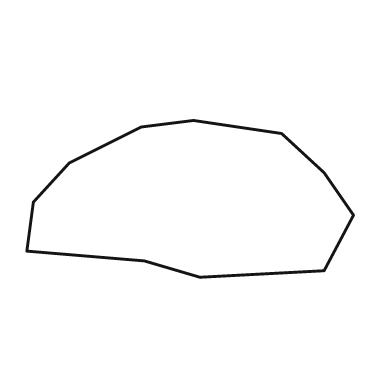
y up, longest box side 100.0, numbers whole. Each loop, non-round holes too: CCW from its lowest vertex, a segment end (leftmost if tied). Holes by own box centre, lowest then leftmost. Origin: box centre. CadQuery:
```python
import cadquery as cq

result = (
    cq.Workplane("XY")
    .moveTo(3.0, -24.0)
    .lineTo(41.0, -22.0)
    .lineTo(50.0, -5.0)
    .lineTo(41.0, 8.0)
    .lineTo(28.0, 20.0)
    .lineTo(1.0, 24.0)
    .lineTo(-15.0, 22.0)
    .lineTo(-37.0, 11.0)
    .lineTo(-48.0, -1.0)
    .lineTo(-50.0, -16.0)
    .lineTo(-14.0, -19.0)
    .close()
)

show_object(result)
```